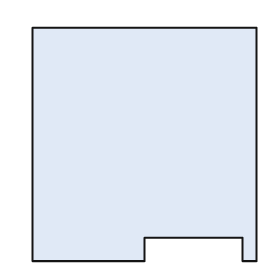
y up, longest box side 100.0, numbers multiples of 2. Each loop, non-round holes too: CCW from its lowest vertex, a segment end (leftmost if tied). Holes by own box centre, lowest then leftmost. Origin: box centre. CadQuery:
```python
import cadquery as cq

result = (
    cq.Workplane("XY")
    .moveTo(-48.0, -50.0)
    .lineTo(0.0, -50.0)
    .lineTo(0.0, -40.0)
    .lineTo(42.0, -40.0)
    .lineTo(42.0, -50.0)
    .lineTo(48.0, -50.0)
    .lineTo(48.0, 50.0)
    .lineTo(-48.0, 50.0)
    .close()
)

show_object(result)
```